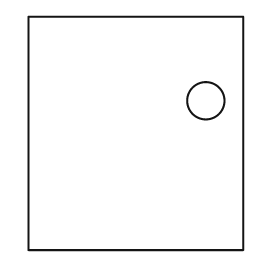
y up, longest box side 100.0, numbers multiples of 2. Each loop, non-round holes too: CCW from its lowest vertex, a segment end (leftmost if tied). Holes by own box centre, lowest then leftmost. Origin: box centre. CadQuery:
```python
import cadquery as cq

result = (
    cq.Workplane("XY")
    .moveTo(-46.0, -50.0)
    .lineTo(46.0, -50.0)
    .lineTo(46.0, 50.0)
    .lineTo(-46.0, 50.0)
    .close()
    .moveTo(30.0, 14.0)
    .circle(8.0)
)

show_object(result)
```